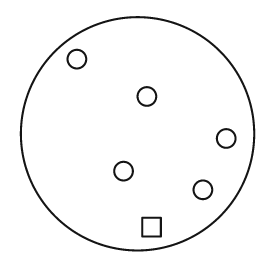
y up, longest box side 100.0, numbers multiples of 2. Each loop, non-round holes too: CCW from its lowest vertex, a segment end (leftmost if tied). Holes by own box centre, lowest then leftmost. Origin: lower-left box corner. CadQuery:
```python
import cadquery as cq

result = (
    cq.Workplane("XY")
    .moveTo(50.0, 50.0)
    .circle(50.0)
    .moveTo(52.0, 6.0)
    .lineTo(60.0, 6.0)
    .lineTo(60.0, 14.0)
    .lineTo(52.0, 14.0)
    .close()
    .moveTo(78.0, 26.0)
    .circle(4.0)
    .moveTo(44.0, 34.0)
    .circle(4.0)
    .moveTo(88.0, 48.0)
    .circle(4.0)
    .moveTo(54.0, 66.0)
    .circle(4.0)
    .moveTo(24.0, 82.0)
    .circle(4.0)
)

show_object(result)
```